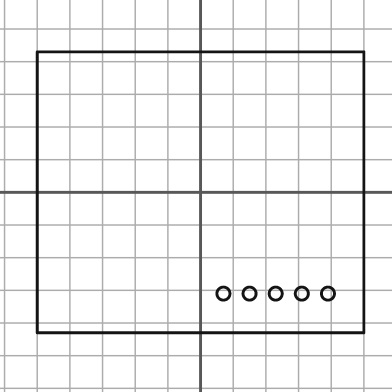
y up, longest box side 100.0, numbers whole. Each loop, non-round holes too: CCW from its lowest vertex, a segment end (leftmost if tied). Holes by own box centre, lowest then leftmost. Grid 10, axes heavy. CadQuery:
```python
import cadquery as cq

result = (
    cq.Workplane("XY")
    .moveTo(-50.0, -43.0)
    .lineTo(50.0, -43.0)
    .lineTo(50.0, 43.0)
    .lineTo(-50.0, 43.0)
    .close()
    .moveTo(7.0, -31.0)
    .circle(2.0)
    .moveTo(15.0, -31.0)
    .circle(2.0)
    .moveTo(23.0, -31.0)
    .circle(2.0)
    .moveTo(31.0, -31.0)
    .circle(2.0)
    .moveTo(39.0, -31.0)
    .circle(2.0)
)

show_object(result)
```